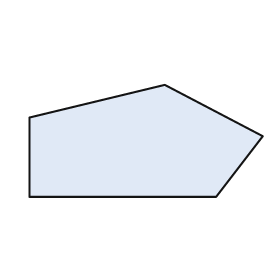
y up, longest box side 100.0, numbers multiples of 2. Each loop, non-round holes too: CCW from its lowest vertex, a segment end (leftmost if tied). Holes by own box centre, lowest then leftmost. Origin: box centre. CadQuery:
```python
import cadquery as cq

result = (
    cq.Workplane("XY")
    .moveTo(-50.0, -24.0)
    .lineTo(30.0, -24.0)
    .lineTo(50.0, 2.0)
    .lineTo(8.0, 24.0)
    .lineTo(-50.0, 10.0)
    .close()
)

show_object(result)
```